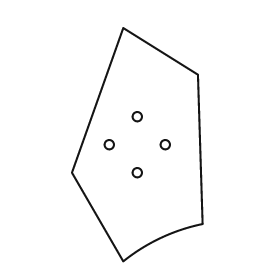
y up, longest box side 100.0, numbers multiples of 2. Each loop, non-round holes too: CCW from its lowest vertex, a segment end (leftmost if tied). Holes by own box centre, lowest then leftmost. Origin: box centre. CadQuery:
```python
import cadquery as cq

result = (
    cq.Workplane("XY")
    .moveTo(-6.0, -50.0)
    .threePointArc((10.0, -40.0), (28.0, -34.0))
    .lineTo(26.0, 30.0)
    .lineTo(-6.0, 50.0)
    .lineTo(-28.0, -12.0)
    .close()
    .moveTo(0.0, -12.0)
    .circle(2.0)
    .moveTo(-12.0, 0.0)
    .circle(2.0)
    .moveTo(12.0, 0.0)
    .circle(2.0)
    .moveTo(0.0, 12.0)
    .circle(2.0)
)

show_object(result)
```